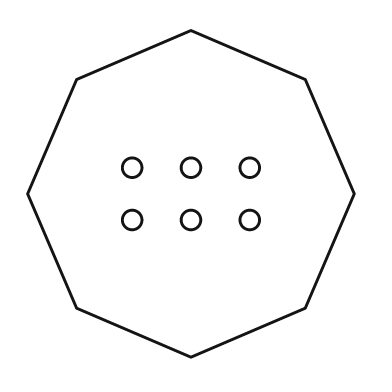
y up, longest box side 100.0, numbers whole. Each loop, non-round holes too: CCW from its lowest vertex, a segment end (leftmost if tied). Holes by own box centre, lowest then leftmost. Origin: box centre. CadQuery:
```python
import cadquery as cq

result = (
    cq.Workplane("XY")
    .moveTo(0.0, -50.0)
    .lineTo(35.0, -35.0)
    .lineTo(50.0, 0.0)
    .lineTo(35.0, 35.0)
    .lineTo(0.0, 50.0)
    .lineTo(-35.0, 35.0)
    .lineTo(-50.0, 0.0)
    .lineTo(-35.0, -35.0)
    .close()
    .moveTo(-18.0, -8.0)
    .circle(3.0)
    .moveTo(0.0, -8.0)
    .circle(3.0)
    .moveTo(18.0, -8.0)
    .circle(3.0)
    .moveTo(-18.0, 8.0)
    .circle(3.0)
    .moveTo(0.0, 8.0)
    .circle(3.0)
    .moveTo(18.0, 8.0)
    .circle(3.0)
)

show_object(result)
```